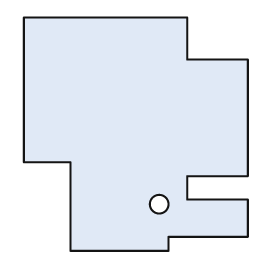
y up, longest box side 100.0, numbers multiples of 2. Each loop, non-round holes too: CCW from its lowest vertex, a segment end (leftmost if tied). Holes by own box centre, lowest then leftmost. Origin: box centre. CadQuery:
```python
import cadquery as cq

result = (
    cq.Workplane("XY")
    .moveTo(-28.0, -50.0)
    .lineTo(14.0, -50.0)
    .lineTo(14.0, -44.0)
    .lineTo(48.0, -44.0)
    .lineTo(48.0, -28.0)
    .lineTo(22.0, -28.0)
    .lineTo(22.0, -18.0)
    .lineTo(48.0, -18.0)
    .lineTo(48.0, 32.0)
    .lineTo(22.0, 32.0)
    .lineTo(22.0, 50.0)
    .lineTo(-48.0, 50.0)
    .lineTo(-48.0, -12.0)
    .lineTo(-28.0, -12.0)
    .close()
    .moveTo(10.0, -30.0)
    .circle(4.0)
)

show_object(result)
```